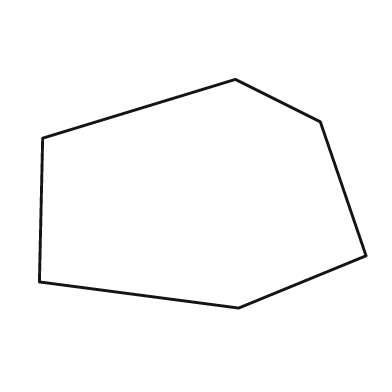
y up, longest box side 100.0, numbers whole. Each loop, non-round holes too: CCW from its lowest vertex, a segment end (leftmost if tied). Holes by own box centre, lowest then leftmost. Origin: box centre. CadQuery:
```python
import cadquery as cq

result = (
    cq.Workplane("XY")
    .moveTo(11.0, -35.0)
    .lineTo(50.0, -19.0)
    .lineTo(36.0, 22.0)
    .lineTo(10.0, 35.0)
    .lineTo(-49.0, 17.0)
    .lineTo(-50.0, -27.0)
    .close()
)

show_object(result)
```